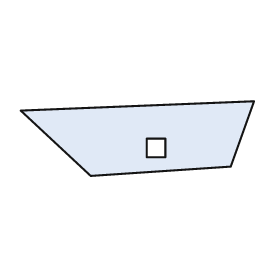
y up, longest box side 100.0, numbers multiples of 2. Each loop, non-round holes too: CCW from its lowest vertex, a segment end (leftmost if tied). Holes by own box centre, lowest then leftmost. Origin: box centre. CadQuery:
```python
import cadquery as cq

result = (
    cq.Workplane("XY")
    .moveTo(-20.0, -16.0)
    .lineTo(40.0, -12.0)
    .lineTo(50.0, 16.0)
    .lineTo(-50.0, 12.0)
    .close()
    .moveTo(4.0, -8.0)
    .lineTo(12.0, -8.0)
    .lineTo(12.0, 0.0)
    .lineTo(4.0, 0.0)
    .close()
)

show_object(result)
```